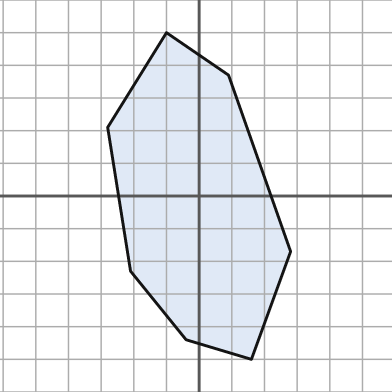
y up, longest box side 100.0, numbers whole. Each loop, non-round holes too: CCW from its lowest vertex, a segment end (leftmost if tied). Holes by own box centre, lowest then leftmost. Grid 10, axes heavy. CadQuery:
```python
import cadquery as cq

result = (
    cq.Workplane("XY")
    .moveTo(16.0, -50.0)
    .lineTo(28.0, -17.0)
    .lineTo(9.0, 37.0)
    .lineTo(-10.0, 50.0)
    .lineTo(-28.0, 21.0)
    .lineTo(-21.0, -23.0)
    .lineTo(-4.0, -44.0)
    .close()
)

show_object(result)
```